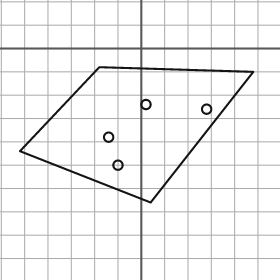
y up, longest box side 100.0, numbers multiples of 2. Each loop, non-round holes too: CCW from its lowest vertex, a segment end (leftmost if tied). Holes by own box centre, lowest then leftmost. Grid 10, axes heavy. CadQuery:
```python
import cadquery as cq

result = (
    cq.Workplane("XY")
    .moveTo(4.0, -66.0)
    .lineTo(48.0, -10.0)
    .lineTo(-18.0, -8.0)
    .lineTo(-52.0, -44.0)
    .close()
    .moveTo(-10.0, -50.0)
    .circle(2.0)
    .moveTo(-14.0, -38.0)
    .circle(2.0)
    .moveTo(28.0, -26.0)
    .circle(2.0)
    .moveTo(2.0, -24.0)
    .circle(2.0)
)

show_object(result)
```